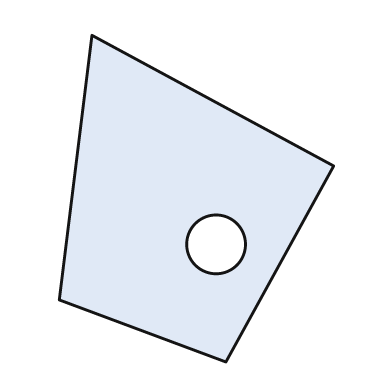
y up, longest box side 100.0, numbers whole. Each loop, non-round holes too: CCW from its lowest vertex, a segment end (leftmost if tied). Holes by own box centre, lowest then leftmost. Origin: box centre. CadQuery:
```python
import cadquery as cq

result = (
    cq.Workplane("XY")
    .moveTo(9.0, -50.0)
    .lineTo(42.0, 10.0)
    .lineTo(-32.0, 50.0)
    .lineTo(-42.0, -31.0)
    .close()
    .moveTo(6.0, -14.0)
    .circle(9.0)
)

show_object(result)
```